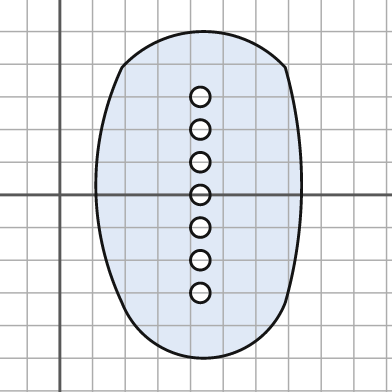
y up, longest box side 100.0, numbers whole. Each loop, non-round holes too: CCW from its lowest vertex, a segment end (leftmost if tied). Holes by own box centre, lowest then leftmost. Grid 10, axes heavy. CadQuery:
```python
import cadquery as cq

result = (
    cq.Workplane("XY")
    .moveTo(19.0, -33.0)
    .threePointArc((44.0, -50.0), (69.0, -33.0))
    .threePointArc((74.0, 3.0), (69.0, 39.0))
    .threePointArc((44.0, 50.0), (19.0, 39.0))
    .threePointArc((11.0, 3.0), (19.0, -33.0))
    .close()
    .moveTo(43.0, -30.0)
    .circle(3.0)
    .moveTo(43.0, -20.0)
    .circle(3.0)
    .moveTo(43.0, -10.0)
    .circle(3.0)
    .moveTo(43.0, 0.0)
    .circle(3.0)
    .moveTo(43.0, 10.0)
    .circle(3.0)
    .moveTo(43.0, 20.0)
    .circle(3.0)
    .moveTo(43.0, 30.0)
    .circle(3.0)
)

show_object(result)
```